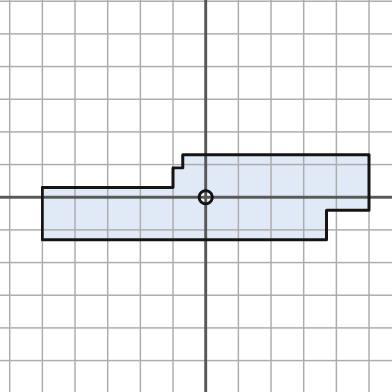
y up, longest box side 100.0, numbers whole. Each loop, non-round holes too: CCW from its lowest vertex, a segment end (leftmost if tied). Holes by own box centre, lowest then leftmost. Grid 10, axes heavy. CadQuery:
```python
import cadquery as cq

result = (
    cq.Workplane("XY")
    .moveTo(-50.0, -13.0)
    .lineTo(37.0, -13.0)
    .lineTo(37.0, -4.0)
    .lineTo(50.0, -4.0)
    .lineTo(50.0, 13.0)
    .lineTo(-7.0, 13.0)
    .lineTo(-7.0, 9.0)
    .lineTo(-10.0, 9.0)
    .lineTo(-10.0, 3.0)
    .lineTo(-50.0, 3.0)
    .close()
    .moveTo(0.0, 0.0)
    .circle(2.0)
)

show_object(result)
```